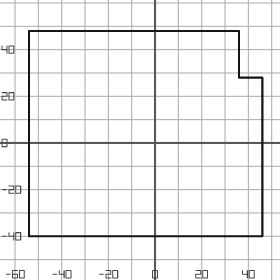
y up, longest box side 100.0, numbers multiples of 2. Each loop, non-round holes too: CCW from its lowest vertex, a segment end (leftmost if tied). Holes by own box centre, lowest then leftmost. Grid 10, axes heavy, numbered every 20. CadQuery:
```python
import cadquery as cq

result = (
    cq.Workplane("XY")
    .moveTo(-54.0, -40.0)
    .lineTo(46.0, -40.0)
    .lineTo(46.0, 28.0)
    .lineTo(36.0, 28.0)
    .lineTo(36.0, 48.0)
    .lineTo(-54.0, 48.0)
    .close()
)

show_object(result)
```